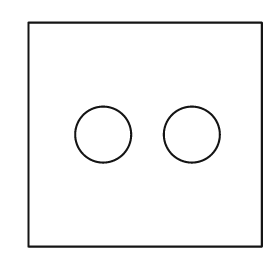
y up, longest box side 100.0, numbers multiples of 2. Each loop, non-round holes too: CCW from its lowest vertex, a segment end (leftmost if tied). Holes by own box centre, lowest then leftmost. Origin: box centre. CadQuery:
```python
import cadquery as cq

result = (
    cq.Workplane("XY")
    .moveTo(-50.0, -48.0)
    .lineTo(50.0, -48.0)
    .lineTo(50.0, 48.0)
    .lineTo(-50.0, 48.0)
    .close()
    .moveTo(-18.0, 0.0)
    .circle(12.0)
    .moveTo(20.0, 0.0)
    .circle(12.0)
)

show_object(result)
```